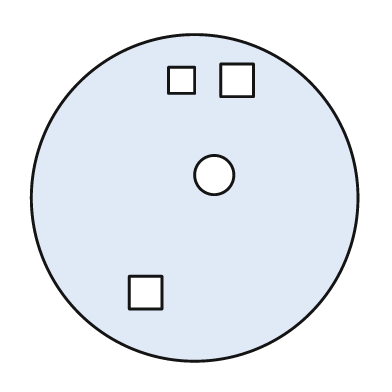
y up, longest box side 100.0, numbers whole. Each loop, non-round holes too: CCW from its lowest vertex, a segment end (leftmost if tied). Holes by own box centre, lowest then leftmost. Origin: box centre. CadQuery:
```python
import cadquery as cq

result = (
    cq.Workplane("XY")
    .moveTo(0.0, 0.0)
    .circle(50.0)
    .moveTo(-20.0, -34.0)
    .lineTo(-10.0, -34.0)
    .lineTo(-10.0, -24.0)
    .lineTo(-20.0, -24.0)
    .close()
    .moveTo(6.0, 7.0)
    .circle(6.0)
    .moveTo(-8.0, 32.0)
    .lineTo(0.0, 32.0)
    .lineTo(0.0, 40.0)
    .lineTo(-8.0, 40.0)
    .close()
    .moveTo(8.0, 31.0)
    .lineTo(18.0, 31.0)
    .lineTo(18.0, 41.0)
    .lineTo(8.0, 41.0)
    .close()
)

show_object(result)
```